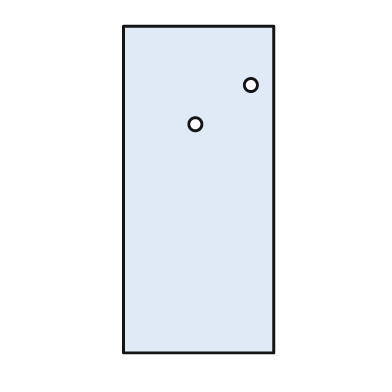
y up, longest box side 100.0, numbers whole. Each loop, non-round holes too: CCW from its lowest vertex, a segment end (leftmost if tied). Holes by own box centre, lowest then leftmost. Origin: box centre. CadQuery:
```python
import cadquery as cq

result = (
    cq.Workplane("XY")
    .moveTo(-23.0, -50.0)
    .lineTo(23.0, -50.0)
    .lineTo(23.0, 50.0)
    .lineTo(-23.0, 50.0)
    .close()
    .moveTo(-1.0, 20.0)
    .circle(2.0)
    .moveTo(16.0, 32.0)
    .circle(2.0)
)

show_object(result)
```